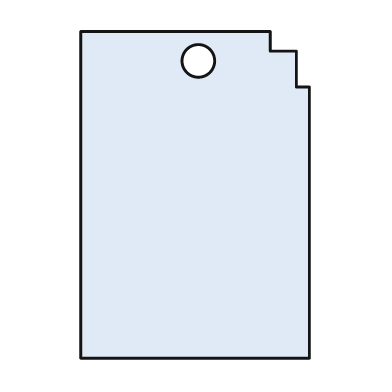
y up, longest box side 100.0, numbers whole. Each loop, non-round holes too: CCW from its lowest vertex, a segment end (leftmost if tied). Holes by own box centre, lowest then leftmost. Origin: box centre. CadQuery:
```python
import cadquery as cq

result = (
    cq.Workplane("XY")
    .moveTo(-35.0, -50.0)
    .lineTo(35.0, -50.0)
    .lineTo(35.0, 33.0)
    .lineTo(31.0, 33.0)
    .lineTo(31.0, 44.0)
    .lineTo(23.0, 44.0)
    .lineTo(23.0, 50.0)
    .lineTo(-35.0, 50.0)
    .close()
    .moveTo(1.0, 41.0)
    .circle(5.0)
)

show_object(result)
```